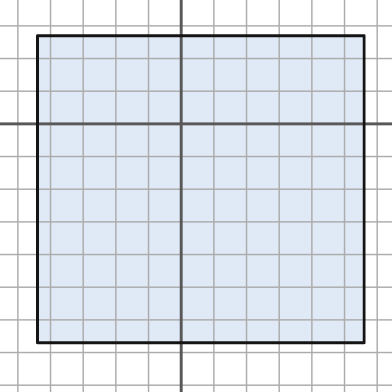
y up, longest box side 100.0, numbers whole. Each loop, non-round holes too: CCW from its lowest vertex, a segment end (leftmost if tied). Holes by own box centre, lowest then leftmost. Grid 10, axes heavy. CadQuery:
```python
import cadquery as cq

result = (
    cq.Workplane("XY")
    .moveTo(-44.0, -67.0)
    .lineTo(56.0, -67.0)
    .lineTo(56.0, 27.0)
    .lineTo(-44.0, 27.0)
    .close()
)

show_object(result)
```